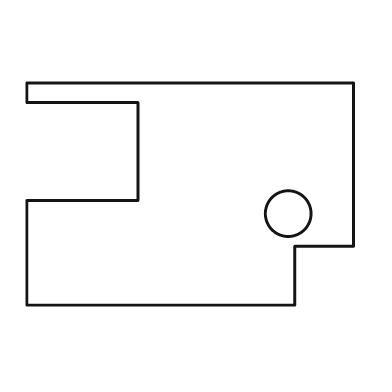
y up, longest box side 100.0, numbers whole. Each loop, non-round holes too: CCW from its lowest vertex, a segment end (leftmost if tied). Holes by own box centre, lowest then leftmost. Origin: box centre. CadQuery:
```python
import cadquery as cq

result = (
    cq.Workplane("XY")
    .moveTo(-50.0, -34.0)
    .lineTo(32.0, -34.0)
    .lineTo(32.0, -16.0)
    .lineTo(50.0, -16.0)
    .lineTo(50.0, 34.0)
    .lineTo(-50.0, 34.0)
    .lineTo(-50.0, 28.0)
    .lineTo(-16.0, 28.0)
    .lineTo(-16.0, -2.0)
    .lineTo(-50.0, -2.0)
    .close()
    .moveTo(30.0, -6.0)
    .circle(7.0)
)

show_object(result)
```